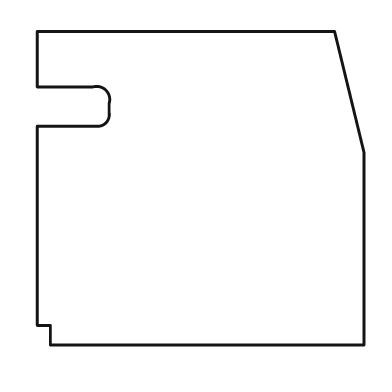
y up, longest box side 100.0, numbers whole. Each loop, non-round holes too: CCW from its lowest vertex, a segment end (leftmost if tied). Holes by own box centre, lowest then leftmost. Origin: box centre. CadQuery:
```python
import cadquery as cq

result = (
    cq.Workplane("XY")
    .moveTo(-46.0, -48.0)
    .lineTo(50.0, -48.0)
    .lineTo(50.0, 11.0)
    .lineTo(41.0, 48.0)
    .lineTo(-50.0, 48.0)
    .lineTo(-50.0, 31.0)
    .lineTo(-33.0, 31.0)
    .threePointArc((-29.0, 30.0), (-28.0, 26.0))
    .lineTo(-28.0, 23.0)
    .threePointArc((-29.0, 20.0), (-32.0, 19.0))
    .lineTo(-50.0, 19.0)
    .lineTo(-50.0, -42.0)
    .lineTo(-46.0, -42.0)
    .close()
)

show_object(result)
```